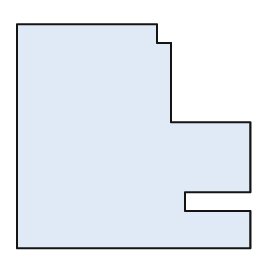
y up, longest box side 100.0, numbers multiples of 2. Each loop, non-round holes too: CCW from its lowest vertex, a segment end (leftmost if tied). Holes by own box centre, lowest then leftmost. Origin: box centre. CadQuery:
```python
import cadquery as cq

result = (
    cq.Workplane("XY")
    .moveTo(-50.0, -48.0)
    .lineTo(50.0, -48.0)
    .lineTo(50.0, -32.0)
    .lineTo(22.0, -32.0)
    .lineTo(22.0, -24.0)
    .lineTo(50.0, -24.0)
    .lineTo(50.0, 6.0)
    .lineTo(16.0, 6.0)
    .lineTo(16.0, 40.0)
    .lineTo(10.0, 40.0)
    .lineTo(10.0, 48.0)
    .lineTo(-50.0, 48.0)
    .close()
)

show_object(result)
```